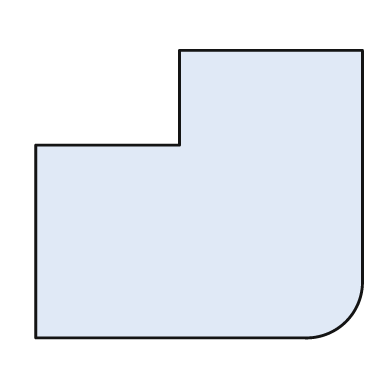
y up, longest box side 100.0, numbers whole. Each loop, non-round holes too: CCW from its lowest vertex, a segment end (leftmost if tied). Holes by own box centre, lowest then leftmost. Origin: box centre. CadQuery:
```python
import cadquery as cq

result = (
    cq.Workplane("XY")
    .moveTo(-50.0, -44.0)
    .lineTo(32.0, -44.0)
    .threePointArc((45.0, -39.0), (50.0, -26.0))
    .lineTo(50.0, 44.0)
    .lineTo(-6.0, 44.0)
    .lineTo(-6.0, 15.0)
    .lineTo(-50.0, 15.0)
    .close()
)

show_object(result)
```